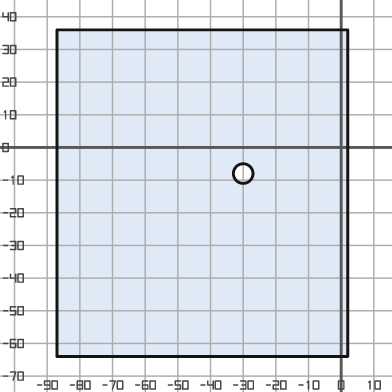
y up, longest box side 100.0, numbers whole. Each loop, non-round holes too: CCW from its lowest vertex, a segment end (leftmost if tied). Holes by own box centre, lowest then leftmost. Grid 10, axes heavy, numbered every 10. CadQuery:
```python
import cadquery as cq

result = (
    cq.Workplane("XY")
    .moveTo(-87.0, -64.0)
    .lineTo(2.0, -64.0)
    .lineTo(2.0, 36.0)
    .lineTo(-87.0, 36.0)
    .close()
    .moveTo(-30.0, -8.0)
    .circle(3.0)
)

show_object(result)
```